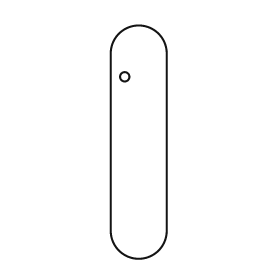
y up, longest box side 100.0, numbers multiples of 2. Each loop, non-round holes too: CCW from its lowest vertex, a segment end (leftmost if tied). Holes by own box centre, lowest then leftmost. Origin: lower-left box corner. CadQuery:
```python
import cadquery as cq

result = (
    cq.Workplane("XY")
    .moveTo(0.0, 12.0)
    .threePointArc((12.0, 0.0), (24.0, 12.0))
    .lineTo(24.0, 88.0)
    .threePointArc((12.0, 100.0), (0.0, 88.0))
    .close()
    .moveTo(6.0, 78.0)
    .circle(2.0)
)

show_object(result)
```